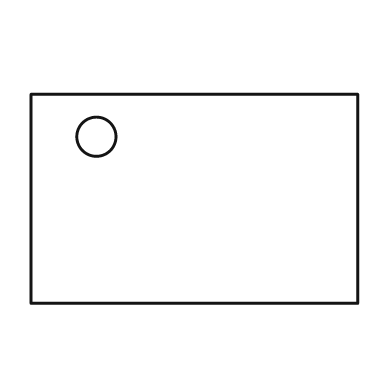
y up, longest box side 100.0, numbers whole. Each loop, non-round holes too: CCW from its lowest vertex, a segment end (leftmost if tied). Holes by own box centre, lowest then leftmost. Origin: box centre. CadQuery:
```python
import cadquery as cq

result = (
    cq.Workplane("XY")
    .moveTo(-50.0, -32.0)
    .lineTo(50.0, -32.0)
    .lineTo(50.0, 32.0)
    .lineTo(-50.0, 32.0)
    .close()
    .moveTo(-30.0, 19.0)
    .circle(6.0)
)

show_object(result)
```